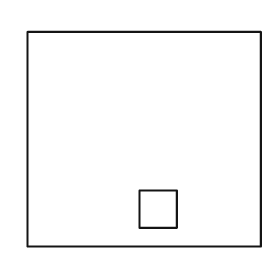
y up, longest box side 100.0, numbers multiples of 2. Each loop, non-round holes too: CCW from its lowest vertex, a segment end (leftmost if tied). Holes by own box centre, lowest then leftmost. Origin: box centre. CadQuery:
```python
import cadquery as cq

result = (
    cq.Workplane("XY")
    .moveTo(-50.0, -46.0)
    .lineTo(50.0, -46.0)
    .lineTo(50.0, 46.0)
    .lineTo(-50.0, 46.0)
    .close()
    .moveTo(-2.0, -38.0)
    .lineTo(14.0, -38.0)
    .lineTo(14.0, -22.0)
    .lineTo(-2.0, -22.0)
    .close()
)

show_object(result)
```